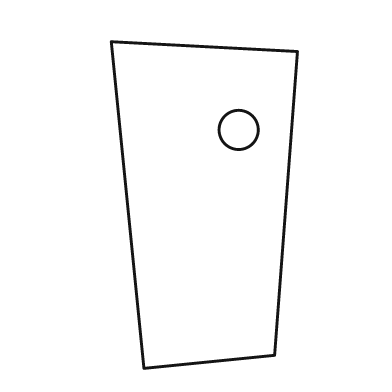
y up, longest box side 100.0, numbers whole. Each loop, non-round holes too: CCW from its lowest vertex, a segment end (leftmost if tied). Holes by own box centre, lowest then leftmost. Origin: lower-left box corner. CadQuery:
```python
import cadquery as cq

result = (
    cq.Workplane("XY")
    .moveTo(10.0, 0.0)
    .lineTo(50.0, 4.0)
    .lineTo(57.0, 97.0)
    .lineTo(0.0, 100.0)
    .close()
    .moveTo(39.0, 73.0)
    .circle(6.0)
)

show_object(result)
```